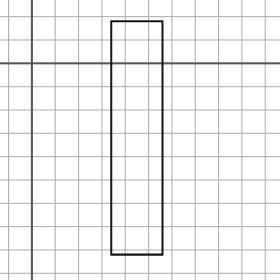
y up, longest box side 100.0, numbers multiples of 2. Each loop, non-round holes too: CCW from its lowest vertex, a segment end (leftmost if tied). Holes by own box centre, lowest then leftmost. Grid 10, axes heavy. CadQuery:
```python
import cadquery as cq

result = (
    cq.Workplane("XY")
    .moveTo(34.0, -82.0)
    .lineTo(56.0, -82.0)
    .lineTo(56.0, 18.0)
    .lineTo(34.0, 18.0)
    .close()
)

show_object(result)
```